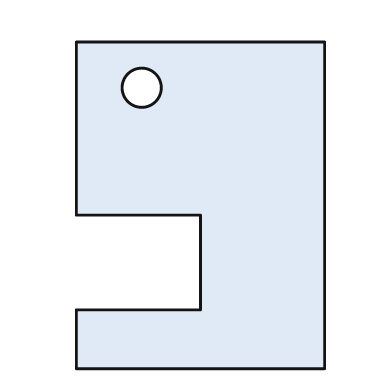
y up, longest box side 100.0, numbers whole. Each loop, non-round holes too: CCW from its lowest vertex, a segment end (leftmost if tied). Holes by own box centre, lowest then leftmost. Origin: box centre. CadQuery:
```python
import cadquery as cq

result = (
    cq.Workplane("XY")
    .moveTo(-38.0, -50.0)
    .lineTo(38.0, -50.0)
    .lineTo(38.0, 50.0)
    .lineTo(-38.0, 50.0)
    .lineTo(-38.0, -3.0)
    .lineTo(0.0, -3.0)
    .lineTo(0.0, -32.0)
    .lineTo(-38.0, -32.0)
    .close()
    .moveTo(-18.0, 36.0)
    .circle(6.0)
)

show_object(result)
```